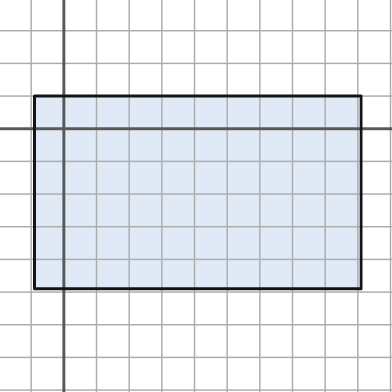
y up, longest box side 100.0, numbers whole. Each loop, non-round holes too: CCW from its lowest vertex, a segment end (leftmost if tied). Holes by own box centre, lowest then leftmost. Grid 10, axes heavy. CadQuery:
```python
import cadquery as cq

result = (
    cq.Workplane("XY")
    .moveTo(-9.0, -49.0)
    .lineTo(91.0, -49.0)
    .lineTo(91.0, 10.0)
    .lineTo(-9.0, 10.0)
    .close()
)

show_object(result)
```